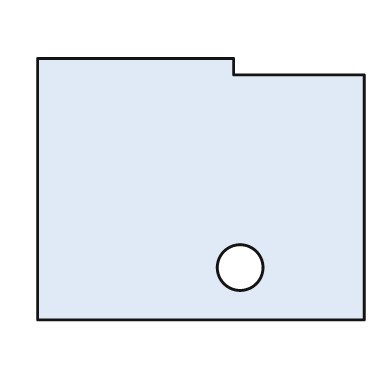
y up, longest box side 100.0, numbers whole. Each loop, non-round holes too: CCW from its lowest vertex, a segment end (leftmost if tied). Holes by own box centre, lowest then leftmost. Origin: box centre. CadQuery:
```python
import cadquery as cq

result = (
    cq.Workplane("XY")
    .moveTo(-50.0, -40.0)
    .lineTo(50.0, -40.0)
    .lineTo(50.0, 35.0)
    .lineTo(10.0, 35.0)
    .lineTo(10.0, 40.0)
    .lineTo(-50.0, 40.0)
    .close()
    .moveTo(12.0, -24.0)
    .circle(7.0)
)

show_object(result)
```